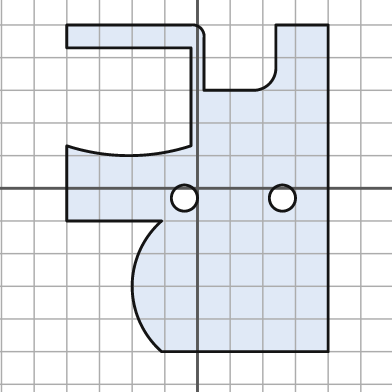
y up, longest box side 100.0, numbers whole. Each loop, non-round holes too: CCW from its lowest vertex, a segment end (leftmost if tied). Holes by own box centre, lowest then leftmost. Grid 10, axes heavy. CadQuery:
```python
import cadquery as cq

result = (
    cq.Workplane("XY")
    .moveTo(-11.0, -50.0)
    .lineTo(40.0, -50.0)
    .lineTo(40.0, 50.0)
    .lineTo(24.0, 50.0)
    .lineTo(24.0, 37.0)
    .threePointArc((22.0, 32.0), (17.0, 30.0))
    .lineTo(2.0, 30.0)
    .lineTo(2.0, 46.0)
    .threePointArc((1.0, 49.0), (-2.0, 50.0))
    .lineTo(-40.0, 50.0)
    .lineTo(-40.0, 43.0)
    .lineTo(-2.0, 43.0)
    .lineTo(-2.0, 13.0)
    .threePointArc((-21.0, 10.0), (-40.0, 13.0))
    .lineTo(-40.0, -10.0)
    .lineTo(-11.0, -10.0)
    .threePointArc((-20.0, -30.0), (-11.0, -50.0))
    .close()
    .moveTo(-4.0, -3.0)
    .circle(4.0)
    .moveTo(26.0, -3.0)
    .circle(4.0)
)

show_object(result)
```